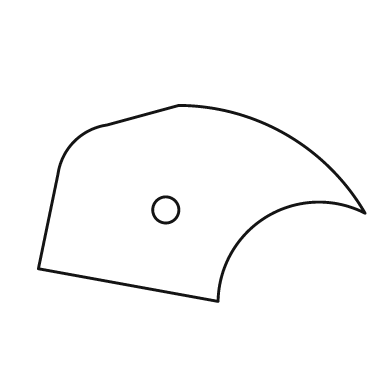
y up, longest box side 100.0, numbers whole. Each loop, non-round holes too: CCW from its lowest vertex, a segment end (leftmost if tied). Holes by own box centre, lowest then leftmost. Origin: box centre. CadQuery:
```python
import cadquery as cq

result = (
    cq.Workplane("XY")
    .moveTo(5.0, -30.0)
    .threePointArc((20.0, -4.0), (50.0, -3.0))
    .threePointArc((26.0, 21.0), (-7.0, 30.0))
    .lineTo(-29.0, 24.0)
    .threePointArc((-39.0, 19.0), (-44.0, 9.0))
    .lineTo(-50.0, -20.0)
    .close()
    .moveTo(-11.0, -2.0)
    .circle(4.0)
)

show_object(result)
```